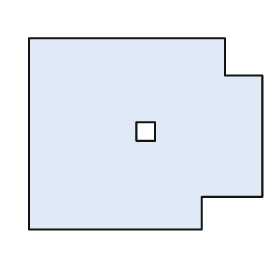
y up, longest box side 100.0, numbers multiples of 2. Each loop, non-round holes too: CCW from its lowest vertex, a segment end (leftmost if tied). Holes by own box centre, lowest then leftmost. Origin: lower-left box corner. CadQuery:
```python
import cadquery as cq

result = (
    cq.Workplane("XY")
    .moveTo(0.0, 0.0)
    .lineTo(74.0, 0.0)
    .lineTo(74.0, 14.0)
    .lineTo(100.0, 14.0)
    .lineTo(100.0, 66.0)
    .lineTo(84.0, 66.0)
    .lineTo(84.0, 82.0)
    .lineTo(0.0, 82.0)
    .close()
    .moveTo(46.0, 38.0)
    .lineTo(54.0, 38.0)
    .lineTo(54.0, 46.0)
    .lineTo(46.0, 46.0)
    .close()
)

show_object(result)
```